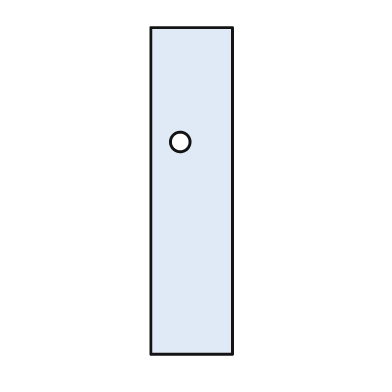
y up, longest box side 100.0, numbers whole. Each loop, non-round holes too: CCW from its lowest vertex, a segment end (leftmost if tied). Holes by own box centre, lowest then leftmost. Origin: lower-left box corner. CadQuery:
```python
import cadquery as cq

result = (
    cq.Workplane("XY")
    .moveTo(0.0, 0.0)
    .lineTo(25.0, 0.0)
    .lineTo(25.0, 100.0)
    .lineTo(0.0, 100.0)
    .close()
    .moveTo(9.0, 65.0)
    .circle(3.0)
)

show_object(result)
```